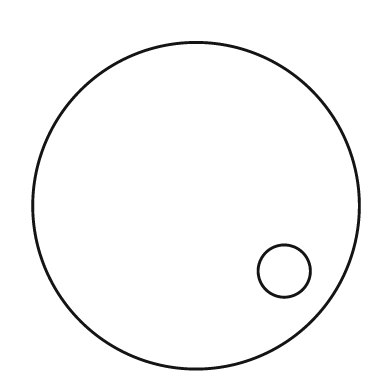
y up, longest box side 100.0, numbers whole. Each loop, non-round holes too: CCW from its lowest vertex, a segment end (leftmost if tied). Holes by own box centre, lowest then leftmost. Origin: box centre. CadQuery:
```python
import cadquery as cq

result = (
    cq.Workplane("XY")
    .moveTo(0.0, 0.0)
    .circle(50.0)
    .moveTo(27.0, -20.0)
    .circle(8.0)
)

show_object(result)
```